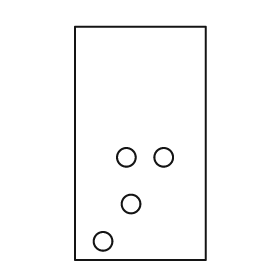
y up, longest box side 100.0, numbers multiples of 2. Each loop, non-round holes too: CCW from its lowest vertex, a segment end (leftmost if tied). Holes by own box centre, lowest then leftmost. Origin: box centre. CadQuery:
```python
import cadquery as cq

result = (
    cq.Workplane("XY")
    .moveTo(-28.0, -50.0)
    .lineTo(28.0, -50.0)
    .lineTo(28.0, 50.0)
    .lineTo(-28.0, 50.0)
    .close()
    .moveTo(-16.0, -42.0)
    .circle(4.0)
    .moveTo(-4.0, -26.0)
    .circle(4.0)
    .moveTo(-6.0, -6.0)
    .circle(4.0)
    .moveTo(10.0, -6.0)
    .circle(4.0)
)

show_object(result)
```